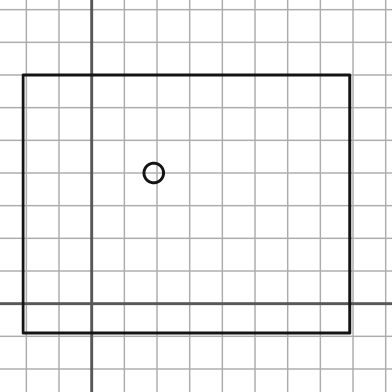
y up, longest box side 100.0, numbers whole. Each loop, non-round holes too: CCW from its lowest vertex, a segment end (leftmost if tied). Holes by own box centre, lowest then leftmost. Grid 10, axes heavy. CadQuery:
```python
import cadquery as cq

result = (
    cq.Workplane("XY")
    .moveTo(-21.0, -9.0)
    .lineTo(79.0, -9.0)
    .lineTo(79.0, 70.0)
    .lineTo(-21.0, 70.0)
    .close()
    .moveTo(19.0, 40.0)
    .circle(3.0)
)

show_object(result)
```